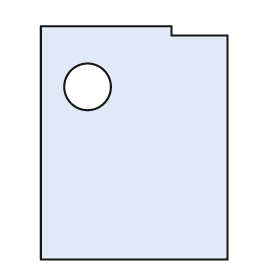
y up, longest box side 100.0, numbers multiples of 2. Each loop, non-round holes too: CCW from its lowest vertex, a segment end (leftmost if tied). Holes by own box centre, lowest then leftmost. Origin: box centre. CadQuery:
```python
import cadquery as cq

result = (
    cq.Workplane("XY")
    .moveTo(-40.0, -50.0)
    .lineTo(40.0, -50.0)
    .lineTo(40.0, 46.0)
    .lineTo(16.0, 46.0)
    .lineTo(16.0, 50.0)
    .lineTo(-40.0, 50.0)
    .close()
    .moveTo(-20.0, 24.0)
    .circle(10.0)
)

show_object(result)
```